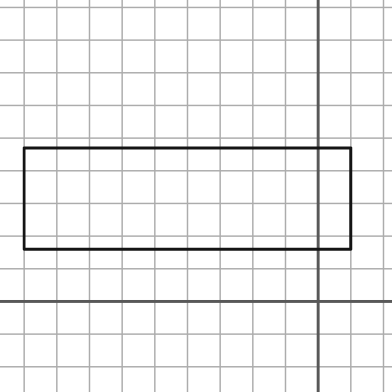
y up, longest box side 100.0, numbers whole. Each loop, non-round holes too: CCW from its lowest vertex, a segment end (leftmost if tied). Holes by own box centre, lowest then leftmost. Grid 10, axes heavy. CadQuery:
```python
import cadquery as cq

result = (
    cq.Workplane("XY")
    .moveTo(-90.0, 16.0)
    .lineTo(10.0, 16.0)
    .lineTo(10.0, 47.0)
    .lineTo(-90.0, 47.0)
    .close()
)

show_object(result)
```